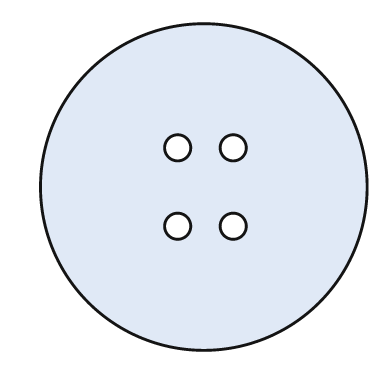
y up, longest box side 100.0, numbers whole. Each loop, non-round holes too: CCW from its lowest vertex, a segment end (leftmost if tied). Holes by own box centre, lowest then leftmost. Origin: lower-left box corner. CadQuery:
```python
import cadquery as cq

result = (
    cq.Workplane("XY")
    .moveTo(50.0, 50.0)
    .circle(50.0)
    .moveTo(42.0, 38.0)
    .circle(4.0)
    .moveTo(59.0, 38.0)
    .circle(4.0)
    .moveTo(42.0, 62.0)
    .circle(4.0)
    .moveTo(59.0, 62.0)
    .circle(4.0)
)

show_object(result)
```